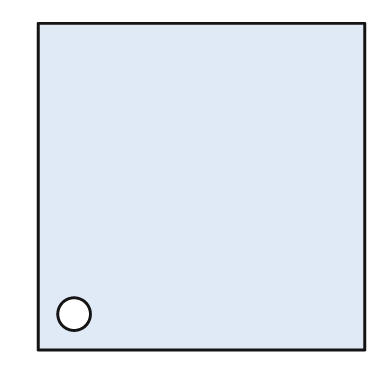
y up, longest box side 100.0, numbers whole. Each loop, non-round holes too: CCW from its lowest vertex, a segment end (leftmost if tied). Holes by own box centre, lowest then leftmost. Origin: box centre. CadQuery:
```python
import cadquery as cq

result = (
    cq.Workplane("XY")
    .moveTo(-50.0, -50.0)
    .lineTo(50.0, -50.0)
    .lineTo(50.0, 50.0)
    .lineTo(-50.0, 50.0)
    .close()
    .moveTo(-39.0, -39.0)
    .circle(5.0)
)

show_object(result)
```